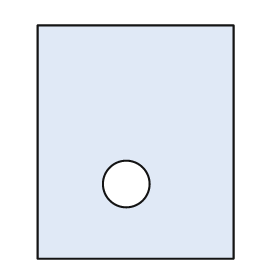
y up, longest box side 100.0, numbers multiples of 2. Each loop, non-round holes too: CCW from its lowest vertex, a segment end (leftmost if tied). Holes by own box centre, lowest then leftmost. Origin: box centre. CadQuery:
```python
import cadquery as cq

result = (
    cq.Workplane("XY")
    .moveTo(-42.0, -50.0)
    .lineTo(42.0, -50.0)
    .lineTo(42.0, 50.0)
    .lineTo(-42.0, 50.0)
    .close()
    .moveTo(-4.0, -18.0)
    .circle(10.0)
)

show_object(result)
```